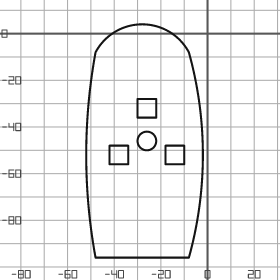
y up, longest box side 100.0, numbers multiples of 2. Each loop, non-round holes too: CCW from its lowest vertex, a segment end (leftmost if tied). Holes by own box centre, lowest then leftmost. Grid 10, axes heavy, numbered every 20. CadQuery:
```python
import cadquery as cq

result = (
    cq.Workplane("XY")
    .moveTo(-48.0, -96.0)
    .lineTo(-8.0, -96.0)
    .threePointArc((-2.0, -52.0), (-8.0, -8.0))
    .threePointArc((-28.0, 4.0), (-48.0, -8.0))
    .threePointArc((-52.0, -52.0), (-48.0, -96.0))
    .close()
    .moveTo(-42.0, -56.0)
    .lineTo(-34.0, -56.0)
    .lineTo(-34.0, -48.0)
    .lineTo(-42.0, -48.0)
    .close()
    .moveTo(-18.0, -56.0)
    .lineTo(-10.0, -56.0)
    .lineTo(-10.0, -48.0)
    .lineTo(-18.0, -48.0)
    .close()
    .moveTo(-26.0, -46.0)
    .circle(4.0)
    .moveTo(-30.0, -36.0)
    .lineTo(-22.0, -36.0)
    .lineTo(-22.0, -28.0)
    .lineTo(-30.0, -28.0)
    .close()
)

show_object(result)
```